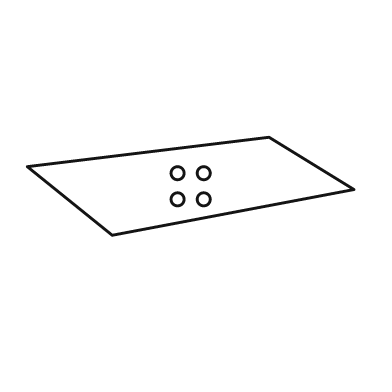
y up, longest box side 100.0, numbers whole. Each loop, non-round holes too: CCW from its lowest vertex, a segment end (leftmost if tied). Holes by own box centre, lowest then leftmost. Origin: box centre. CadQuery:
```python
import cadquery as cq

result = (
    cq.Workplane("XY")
    .moveTo(-24.0, -15.0)
    .lineTo(50.0, -1.0)
    .lineTo(24.0, 15.0)
    .lineTo(-50.0, 6.0)
    .close()
    .moveTo(-4.0, -4.0)
    .circle(2.0)
    .moveTo(4.0, -4.0)
    .circle(2.0)
    .moveTo(-4.0, 4.0)
    .circle(2.0)
    .moveTo(4.0, 4.0)
    .circle(2.0)
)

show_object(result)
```